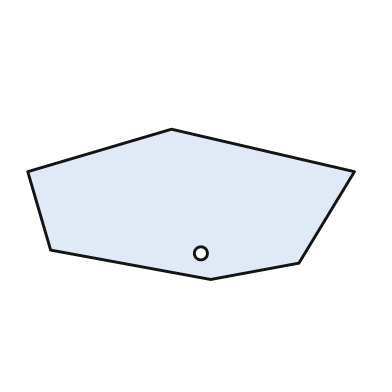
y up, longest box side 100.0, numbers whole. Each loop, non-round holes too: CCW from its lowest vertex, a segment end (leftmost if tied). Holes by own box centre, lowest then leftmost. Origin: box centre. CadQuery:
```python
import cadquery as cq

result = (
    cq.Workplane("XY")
    .moveTo(6.0, -23.0)
    .lineTo(33.0, -18.0)
    .lineTo(50.0, 10.0)
    .lineTo(-6.0, 23.0)
    .lineTo(-50.0, 10.0)
    .lineTo(-43.0, -14.0)
    .close()
    .moveTo(3.0, -15.0)
    .circle(2.0)
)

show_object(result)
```